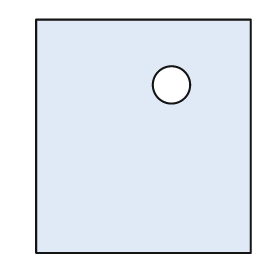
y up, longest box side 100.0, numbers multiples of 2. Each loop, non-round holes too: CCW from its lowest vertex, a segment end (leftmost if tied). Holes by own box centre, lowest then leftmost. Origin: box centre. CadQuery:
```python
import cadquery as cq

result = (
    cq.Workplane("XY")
    .moveTo(-46.0, -50.0)
    .lineTo(46.0, -50.0)
    .lineTo(46.0, 50.0)
    .lineTo(-46.0, 50.0)
    .close()
    .moveTo(12.0, 22.0)
    .circle(8.0)
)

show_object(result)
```